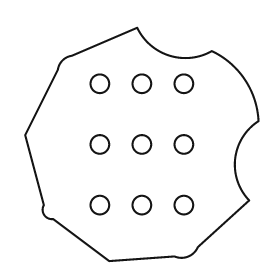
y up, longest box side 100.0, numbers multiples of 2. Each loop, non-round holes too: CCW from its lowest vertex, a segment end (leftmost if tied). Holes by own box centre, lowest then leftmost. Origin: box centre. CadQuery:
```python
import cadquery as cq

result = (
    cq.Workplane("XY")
    .moveTo(-14.0, -50.0)
    .lineTo(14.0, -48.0)
    .threePointArc((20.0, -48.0), (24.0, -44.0))
    .lineTo(46.0, -24.0)
    .threePointArc((40.0, -6.0), (50.0, 10.0))
    .threePointArc((44.0, 28.0), (30.0, 40.0))
    .threePointArc((12.0, 38.0), (-2.0, 50.0))
    .lineTo(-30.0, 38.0)
    .threePointArc((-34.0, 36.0), (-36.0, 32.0))
    .lineTo(-50.0, 4.0)
    .lineTo(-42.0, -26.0)
    .threePointArc((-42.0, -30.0), (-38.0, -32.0))
    .close()
    .moveTo(-18.0, -26.0)
    .circle(4.0)
    .moveTo(0.0, -26.0)
    .circle(4.0)
    .moveTo(18.0, -26.0)
    .circle(4.0)
    .moveTo(-18.0, 0.0)
    .circle(4.0)
    .moveTo(0.0, 0.0)
    .circle(4.0)
    .moveTo(18.0, 0.0)
    .circle(4.0)
    .moveTo(-18.0, 26.0)
    .circle(4.0)
    .moveTo(0.0, 26.0)
    .circle(4.0)
    .moveTo(18.0, 26.0)
    .circle(4.0)
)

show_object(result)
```